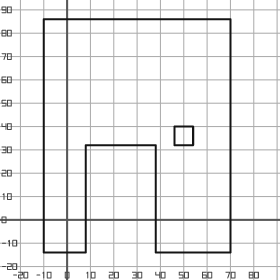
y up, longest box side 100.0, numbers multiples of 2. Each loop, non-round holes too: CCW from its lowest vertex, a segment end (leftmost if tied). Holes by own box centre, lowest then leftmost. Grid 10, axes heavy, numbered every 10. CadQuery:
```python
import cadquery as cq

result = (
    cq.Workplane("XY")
    .moveTo(-10.0, -14.0)
    .lineTo(8.0, -14.0)
    .lineTo(8.0, 32.0)
    .lineTo(38.0, 32.0)
    .lineTo(38.0, -14.0)
    .lineTo(70.0, -14.0)
    .lineTo(70.0, 86.0)
    .lineTo(-10.0, 86.0)
    .close()
    .moveTo(46.0, 32.0)
    .lineTo(54.0, 32.0)
    .lineTo(54.0, 40.0)
    .lineTo(46.0, 40.0)
    .close()
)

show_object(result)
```